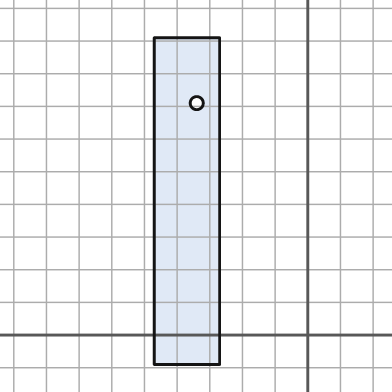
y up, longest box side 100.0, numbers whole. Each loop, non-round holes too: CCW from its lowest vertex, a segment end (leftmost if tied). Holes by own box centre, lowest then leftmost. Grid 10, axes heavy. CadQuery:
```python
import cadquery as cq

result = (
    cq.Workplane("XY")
    .moveTo(-47.0, -9.0)
    .lineTo(-27.0, -9.0)
    .lineTo(-27.0, 91.0)
    .lineTo(-47.0, 91.0)
    .close()
    .moveTo(-34.0, 71.0)
    .circle(2.0)
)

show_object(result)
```